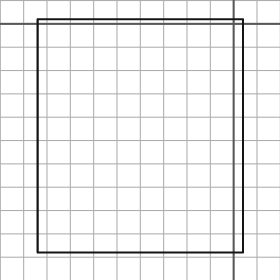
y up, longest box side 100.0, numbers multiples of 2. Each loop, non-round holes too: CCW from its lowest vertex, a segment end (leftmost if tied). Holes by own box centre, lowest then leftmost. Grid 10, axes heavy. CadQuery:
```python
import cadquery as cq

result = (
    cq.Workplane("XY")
    .moveTo(-84.0, -98.0)
    .lineTo(4.0, -98.0)
    .lineTo(4.0, 2.0)
    .lineTo(-84.0, 2.0)
    .close()
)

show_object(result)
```